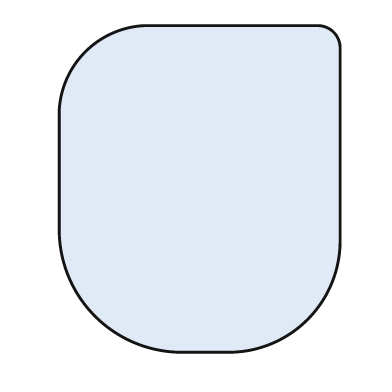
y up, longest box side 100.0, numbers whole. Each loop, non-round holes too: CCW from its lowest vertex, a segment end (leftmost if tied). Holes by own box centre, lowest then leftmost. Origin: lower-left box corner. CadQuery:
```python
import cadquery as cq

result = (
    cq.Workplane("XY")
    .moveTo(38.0, 0.0)
    .lineTo(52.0, 0.0)
    .threePointArc((76.0, 10.0), (86.0, 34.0))
    .lineTo(86.0, 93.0)
    .threePointArc((84.0, 98.0), (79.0, 100.0))
    .lineTo(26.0, 100.0)
    .threePointArc((8.0, 92.0), (0.0, 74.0))
    .lineTo(0.0, 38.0)
    .threePointArc((11.0, 11.0), (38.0, 0.0))
    .close()
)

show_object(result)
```